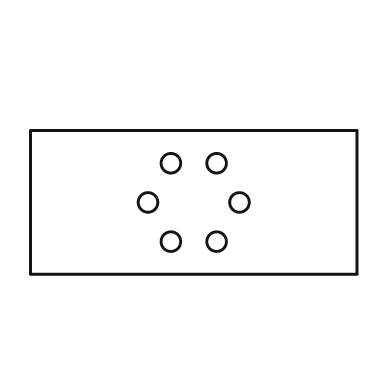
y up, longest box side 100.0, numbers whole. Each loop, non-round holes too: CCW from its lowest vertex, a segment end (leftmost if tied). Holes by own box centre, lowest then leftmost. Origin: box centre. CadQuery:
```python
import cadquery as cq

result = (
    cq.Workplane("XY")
    .moveTo(-50.0, -22.0)
    .lineTo(50.0, -22.0)
    .lineTo(50.0, 22.0)
    .lineTo(-50.0, 22.0)
    .close()
    .moveTo(-7.0, -12.0)
    .circle(3.0)
    .moveTo(7.0, -12.0)
    .circle(3.0)
    .moveTo(-14.0, 0.0)
    .circle(3.0)
    .moveTo(14.0, 0.0)
    .circle(3.0)
    .moveTo(-7.0, 12.0)
    .circle(3.0)
    .moveTo(7.0, 12.0)
    .circle(3.0)
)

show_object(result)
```